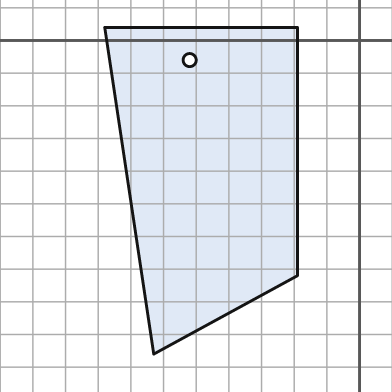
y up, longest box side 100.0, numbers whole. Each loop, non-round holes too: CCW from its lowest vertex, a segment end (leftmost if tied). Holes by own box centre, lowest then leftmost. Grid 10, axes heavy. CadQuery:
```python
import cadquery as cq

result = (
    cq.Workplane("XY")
    .moveTo(-63.0, -96.0)
    .lineTo(-19.0, -72.0)
    .lineTo(-19.0, 4.0)
    .lineTo(-78.0, 4.0)
    .close()
    .moveTo(-52.0, -6.0)
    .circle(2.0)
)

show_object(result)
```